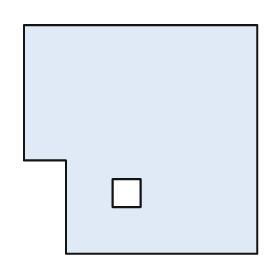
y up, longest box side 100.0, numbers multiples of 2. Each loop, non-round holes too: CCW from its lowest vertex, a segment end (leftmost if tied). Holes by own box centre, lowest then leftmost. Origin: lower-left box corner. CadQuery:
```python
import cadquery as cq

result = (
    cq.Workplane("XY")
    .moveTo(18.0, 0.0)
    .lineTo(100.0, 0.0)
    .lineTo(100.0, 98.0)
    .lineTo(0.0, 98.0)
    .lineTo(0.0, 40.0)
    .lineTo(18.0, 40.0)
    .close()
    .moveTo(38.0, 20.0)
    .lineTo(50.0, 20.0)
    .lineTo(50.0, 32.0)
    .lineTo(38.0, 32.0)
    .close()
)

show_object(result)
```